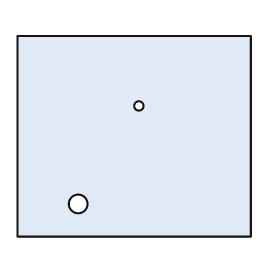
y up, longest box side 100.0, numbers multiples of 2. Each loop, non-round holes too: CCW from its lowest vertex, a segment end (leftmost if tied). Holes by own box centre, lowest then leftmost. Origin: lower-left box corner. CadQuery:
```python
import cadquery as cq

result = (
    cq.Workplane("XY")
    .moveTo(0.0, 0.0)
    .lineTo(100.0, 0.0)
    .lineTo(100.0, 86.0)
    .lineTo(0.0, 86.0)
    .close()
    .moveTo(26.0, 14.0)
    .circle(4.0)
    .moveTo(52.0, 56.0)
    .circle(2.0)
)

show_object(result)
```